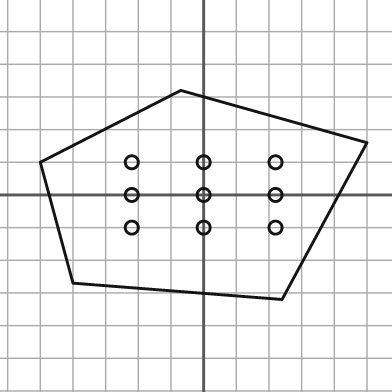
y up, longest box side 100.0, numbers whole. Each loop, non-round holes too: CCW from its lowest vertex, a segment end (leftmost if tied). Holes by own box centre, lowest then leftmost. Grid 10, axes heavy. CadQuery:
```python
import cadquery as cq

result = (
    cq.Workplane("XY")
    .moveTo(24.0, -32.0)
    .lineTo(50.0, 16.0)
    .lineTo(-7.0, 32.0)
    .lineTo(-50.0, 10.0)
    .lineTo(-40.0, -27.0)
    .close()
    .moveTo(-22.0, -10.0)
    .circle(2.0)
    .moveTo(0.0, -10.0)
    .circle(2.0)
    .moveTo(22.0, -10.0)
    .circle(2.0)
    .moveTo(-22.0, 0.0)
    .circle(2.0)
    .moveTo(0.0, 0.0)
    .circle(2.0)
    .moveTo(22.0, 0.0)
    .circle(2.0)
    .moveTo(-22.0, 10.0)
    .circle(2.0)
    .moveTo(0.0, 10.0)
    .circle(2.0)
    .moveTo(22.0, 10.0)
    .circle(2.0)
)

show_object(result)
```